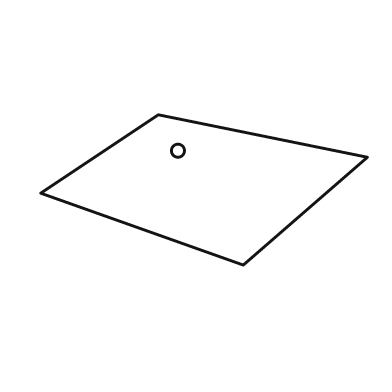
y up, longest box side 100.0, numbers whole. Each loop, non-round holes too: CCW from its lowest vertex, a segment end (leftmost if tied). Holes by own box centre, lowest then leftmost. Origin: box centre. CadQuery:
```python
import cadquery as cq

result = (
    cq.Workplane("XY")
    .moveTo(12.0, -23.0)
    .lineTo(50.0, 10.0)
    .lineTo(-14.0, 23.0)
    .lineTo(-50.0, -1.0)
    .close()
    .moveTo(-8.0, 12.0)
    .circle(2.0)
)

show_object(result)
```